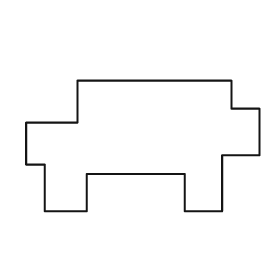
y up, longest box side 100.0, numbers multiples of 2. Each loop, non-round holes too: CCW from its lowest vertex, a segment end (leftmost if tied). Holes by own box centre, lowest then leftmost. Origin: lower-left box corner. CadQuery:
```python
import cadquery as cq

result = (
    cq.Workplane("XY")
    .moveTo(8.0, 0.0)
    .lineTo(26.0, 0.0)
    .lineTo(26.0, 16.0)
    .lineTo(68.0, 16.0)
    .lineTo(68.0, 0.0)
    .lineTo(84.0, 0.0)
    .lineTo(84.0, 24.0)
    .lineTo(100.0, 24.0)
    .lineTo(100.0, 44.0)
    .lineTo(88.0, 44.0)
    .lineTo(88.0, 56.0)
    .lineTo(22.0, 56.0)
    .lineTo(22.0, 38.0)
    .lineTo(0.0, 38.0)
    .lineTo(0.0, 20.0)
    .lineTo(8.0, 20.0)
    .close()
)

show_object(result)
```